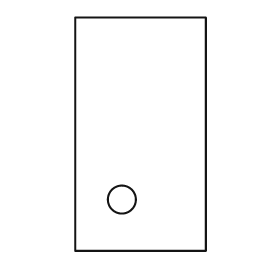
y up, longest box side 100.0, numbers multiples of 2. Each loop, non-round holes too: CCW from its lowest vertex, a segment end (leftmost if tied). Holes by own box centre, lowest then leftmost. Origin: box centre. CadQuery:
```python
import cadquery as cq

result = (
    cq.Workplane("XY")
    .moveTo(-28.0, -50.0)
    .lineTo(28.0, -50.0)
    .lineTo(28.0, 50.0)
    .lineTo(-28.0, 50.0)
    .close()
    .moveTo(-8.0, -28.0)
    .circle(6.0)
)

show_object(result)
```